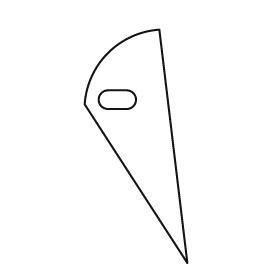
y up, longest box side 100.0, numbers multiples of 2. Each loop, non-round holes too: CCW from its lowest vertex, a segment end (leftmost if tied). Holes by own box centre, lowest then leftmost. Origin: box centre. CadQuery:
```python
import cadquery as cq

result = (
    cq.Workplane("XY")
    .moveTo(22.0, -50.0)
    .lineTo(10.0, 50.0)
    .threePointArc((-12.0, 40.0), (-22.0, 18.0))
    .close()
    .moveTo(-12.0, 16.0)
    .lineTo(-4.0, 16.0)
    .threePointArc((0.0, 20.0), (-4.0, 24.0))
    .lineTo(-12.0, 24.0)
    .threePointArc((-16.0, 20.0), (-12.0, 16.0))
    .close()
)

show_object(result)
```